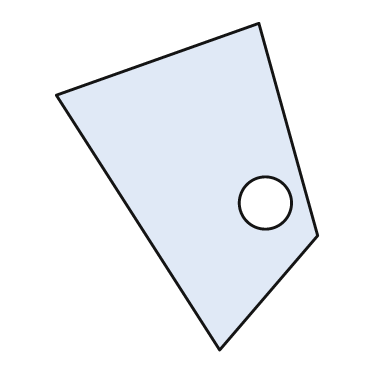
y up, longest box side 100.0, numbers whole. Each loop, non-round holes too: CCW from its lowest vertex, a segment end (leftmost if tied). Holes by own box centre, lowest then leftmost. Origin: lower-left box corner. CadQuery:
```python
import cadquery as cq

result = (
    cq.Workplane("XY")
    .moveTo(50.0, 0.0)
    .lineTo(80.0, 35.0)
    .lineTo(62.0, 100.0)
    .lineTo(0.0, 78.0)
    .close()
    .moveTo(64.0, 45.0)
    .circle(8.0)
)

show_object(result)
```